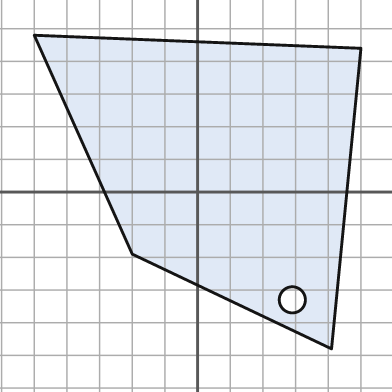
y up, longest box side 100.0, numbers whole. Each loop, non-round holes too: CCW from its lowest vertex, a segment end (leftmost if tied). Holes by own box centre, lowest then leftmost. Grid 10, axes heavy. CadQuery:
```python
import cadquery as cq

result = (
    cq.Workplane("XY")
    .moveTo(41.0, -48.0)
    .lineTo(50.0, 44.0)
    .lineTo(-50.0, 48.0)
    .lineTo(-20.0, -19.0)
    .close()
    .moveTo(29.0, -33.0)
    .circle(4.0)
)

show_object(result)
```